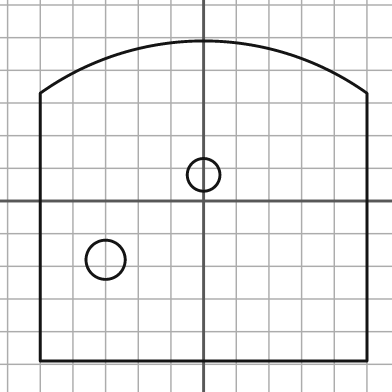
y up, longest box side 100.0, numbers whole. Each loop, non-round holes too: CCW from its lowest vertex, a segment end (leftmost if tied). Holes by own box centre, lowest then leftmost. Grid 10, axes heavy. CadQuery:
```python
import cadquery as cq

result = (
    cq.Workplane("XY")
    .moveTo(-50.0, -49.0)
    .lineTo(50.0, -49.0)
    .lineTo(50.0, 33.0)
    .threePointArc((0.0, 49.0), (-50.0, 33.0))
    .close()
    .moveTo(-30.0, -18.0)
    .circle(6.0)
    .moveTo(0.0, 8.0)
    .circle(5.0)
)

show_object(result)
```